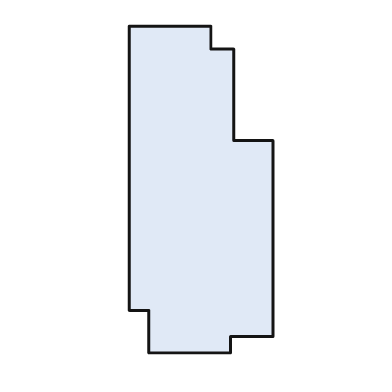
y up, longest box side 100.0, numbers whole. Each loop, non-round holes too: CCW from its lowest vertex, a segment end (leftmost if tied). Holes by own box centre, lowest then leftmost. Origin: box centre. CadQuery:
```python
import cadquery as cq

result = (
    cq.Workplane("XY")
    .moveTo(-16.0, -50.0)
    .lineTo(9.0, -50.0)
    .lineTo(9.0, -45.0)
    .lineTo(22.0, -45.0)
    .lineTo(22.0, 15.0)
    .lineTo(10.0, 15.0)
    .lineTo(10.0, 43.0)
    .lineTo(3.0, 43.0)
    .lineTo(3.0, 50.0)
    .lineTo(-22.0, 50.0)
    .lineTo(-22.0, -37.0)
    .lineTo(-16.0, -37.0)
    .close()
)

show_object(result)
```